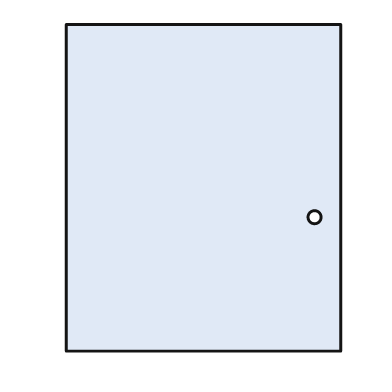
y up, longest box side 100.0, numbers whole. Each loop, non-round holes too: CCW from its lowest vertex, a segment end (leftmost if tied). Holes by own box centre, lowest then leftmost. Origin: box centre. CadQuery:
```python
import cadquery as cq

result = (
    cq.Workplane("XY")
    .moveTo(-42.0, -50.0)
    .lineTo(42.0, -50.0)
    .lineTo(42.0, 50.0)
    .lineTo(-42.0, 50.0)
    .close()
    .moveTo(34.0, -9.0)
    .circle(2.0)
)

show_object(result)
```